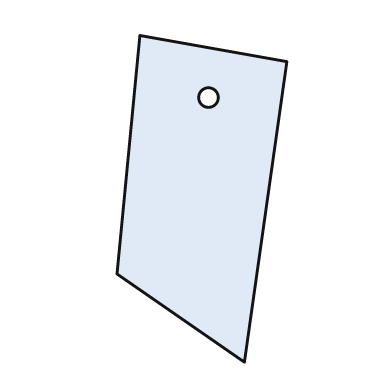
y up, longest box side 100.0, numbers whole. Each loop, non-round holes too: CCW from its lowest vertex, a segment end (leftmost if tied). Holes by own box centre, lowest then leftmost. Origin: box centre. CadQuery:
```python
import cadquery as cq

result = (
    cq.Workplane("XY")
    .moveTo(13.0, -50.0)
    .lineTo(26.0, 42.0)
    .lineTo(-19.0, 50.0)
    .lineTo(-26.0, -23.0)
    .close()
    .moveTo(2.0, 31.0)
    .circle(3.0)
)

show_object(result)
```